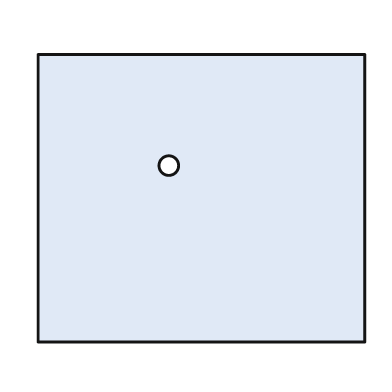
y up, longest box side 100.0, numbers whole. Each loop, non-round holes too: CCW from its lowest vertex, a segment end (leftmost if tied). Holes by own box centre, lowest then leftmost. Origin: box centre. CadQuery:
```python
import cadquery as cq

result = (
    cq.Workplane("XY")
    .moveTo(-50.0, -44.0)
    .lineTo(50.0, -44.0)
    .lineTo(50.0, 44.0)
    .lineTo(-50.0, 44.0)
    .close()
    .moveTo(-10.0, 10.0)
    .circle(3.0)
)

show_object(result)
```